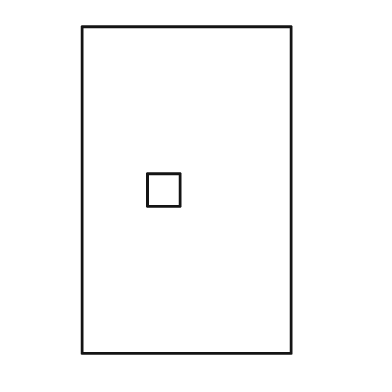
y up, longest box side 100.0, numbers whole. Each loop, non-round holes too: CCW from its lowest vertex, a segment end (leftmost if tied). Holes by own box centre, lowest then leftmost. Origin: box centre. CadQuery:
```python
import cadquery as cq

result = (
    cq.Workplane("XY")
    .moveTo(-32.0, -50.0)
    .lineTo(32.0, -50.0)
    .lineTo(32.0, 50.0)
    .lineTo(-32.0, 50.0)
    .close()
    .moveTo(-12.0, -5.0)
    .lineTo(-2.0, -5.0)
    .lineTo(-2.0, 5.0)
    .lineTo(-12.0, 5.0)
    .close()
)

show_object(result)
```